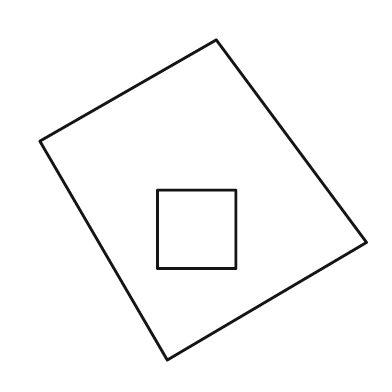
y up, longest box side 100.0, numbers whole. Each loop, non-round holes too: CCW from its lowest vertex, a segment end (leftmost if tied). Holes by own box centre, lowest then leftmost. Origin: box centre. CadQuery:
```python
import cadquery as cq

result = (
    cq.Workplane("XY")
    .moveTo(-11.0, -49.0)
    .lineTo(50.0, -13.0)
    .lineTo(4.0, 49.0)
    .lineTo(-50.0, 18.0)
    .close()
    .moveTo(-14.0, -21.0)
    .lineTo(10.0, -21.0)
    .lineTo(10.0, 3.0)
    .lineTo(-14.0, 3.0)
    .close()
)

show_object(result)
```